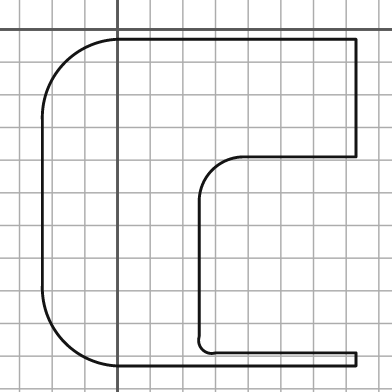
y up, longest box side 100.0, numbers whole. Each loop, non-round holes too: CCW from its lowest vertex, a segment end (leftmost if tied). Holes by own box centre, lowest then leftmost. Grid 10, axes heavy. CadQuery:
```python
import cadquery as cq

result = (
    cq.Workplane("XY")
    .moveTo(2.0, -103.0)
    .lineTo(73.0, -103.0)
    .lineTo(73.0, -99.0)
    .lineTo(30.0, -99.0)
    .threePointArc((26.0, -98.0), (25.0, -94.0))
    .lineTo(25.0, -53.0)
    .threePointArc((29.0, -43.0), (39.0, -39.0))
    .lineTo(73.0, -39.0)
    .lineTo(73.0, -3.0)
    .lineTo(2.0, -3.0)
    .threePointArc((-16.0, -10.0), (-23.0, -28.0))
    .lineTo(-23.0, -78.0)
    .threePointArc((-16.0, -96.0), (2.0, -103.0))
    .close()
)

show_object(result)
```